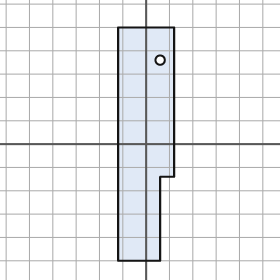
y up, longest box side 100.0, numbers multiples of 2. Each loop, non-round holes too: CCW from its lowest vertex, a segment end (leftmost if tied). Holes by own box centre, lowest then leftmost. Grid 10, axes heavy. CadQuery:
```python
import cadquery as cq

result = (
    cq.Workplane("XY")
    .moveTo(-12.0, -50.0)
    .lineTo(6.0, -50.0)
    .lineTo(6.0, -14.0)
    .lineTo(12.0, -14.0)
    .lineTo(12.0, 50.0)
    .lineTo(-12.0, 50.0)
    .close()
    .moveTo(6.0, 36.0)
    .circle(2.0)
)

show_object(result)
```